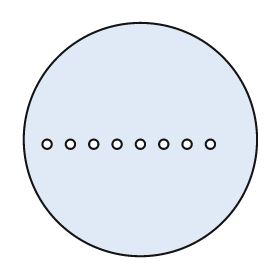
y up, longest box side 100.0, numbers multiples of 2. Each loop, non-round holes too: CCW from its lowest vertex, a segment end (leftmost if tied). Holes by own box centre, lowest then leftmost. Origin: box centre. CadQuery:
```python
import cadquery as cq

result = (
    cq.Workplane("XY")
    .moveTo(0.0, 0.0)
    .circle(50.0)
    .moveTo(-40.0, -2.0)
    .circle(2.0)
    .moveTo(-30.0, -2.0)
    .circle(2.0)
    .moveTo(-20.0, -2.0)
    .circle(2.0)
    .moveTo(-10.0, -2.0)
    .circle(2.0)
    .moveTo(0.0, -2.0)
    .circle(2.0)
    .moveTo(10.0, -2.0)
    .circle(2.0)
    .moveTo(20.0, -2.0)
    .circle(2.0)
    .moveTo(30.0, -2.0)
    .circle(2.0)
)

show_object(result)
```